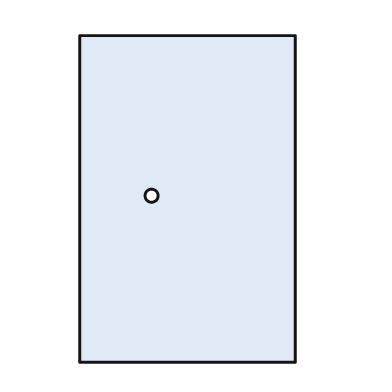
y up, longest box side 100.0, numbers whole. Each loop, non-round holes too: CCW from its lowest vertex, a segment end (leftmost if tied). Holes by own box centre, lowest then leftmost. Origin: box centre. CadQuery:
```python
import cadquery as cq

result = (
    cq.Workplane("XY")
    .moveTo(-33.0, -50.0)
    .lineTo(33.0, -50.0)
    .lineTo(33.0, 50.0)
    .lineTo(-33.0, 50.0)
    .close()
    .moveTo(-11.0, 1.0)
    .circle(2.0)
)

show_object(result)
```